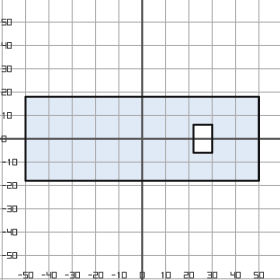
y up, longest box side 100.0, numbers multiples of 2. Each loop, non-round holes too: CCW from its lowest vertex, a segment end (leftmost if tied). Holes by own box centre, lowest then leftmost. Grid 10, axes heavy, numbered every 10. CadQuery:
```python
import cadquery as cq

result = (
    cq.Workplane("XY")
    .moveTo(-50.0, -18.0)
    .lineTo(50.0, -18.0)
    .lineTo(50.0, 18.0)
    .lineTo(-50.0, 18.0)
    .close()
    .moveTo(22.0, -6.0)
    .lineTo(30.0, -6.0)
    .lineTo(30.0, 6.0)
    .lineTo(22.0, 6.0)
    .close()
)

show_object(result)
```